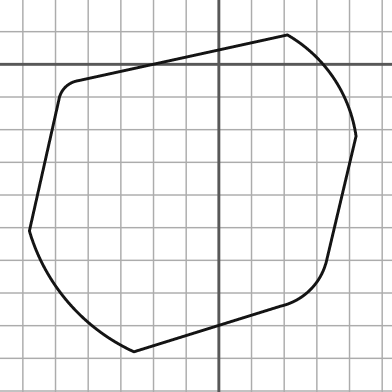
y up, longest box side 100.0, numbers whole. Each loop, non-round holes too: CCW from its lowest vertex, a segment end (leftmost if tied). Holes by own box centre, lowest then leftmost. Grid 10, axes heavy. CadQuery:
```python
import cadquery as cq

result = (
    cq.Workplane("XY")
    .moveTo(-26.0, -88.0)
    .lineTo(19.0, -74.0)
    .threePointArc((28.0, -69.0), (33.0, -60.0))
    .lineTo(42.0, -22.0)
    .threePointArc((35.0, -4.0), (21.0, 9.0))
    .lineTo(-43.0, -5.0)
    .threePointArc((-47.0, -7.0), (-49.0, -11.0))
    .lineTo(-58.0, -51.0)
    .threePointArc((-46.0, -73.0), (-26.0, -88.0))
    .close()
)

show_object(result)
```